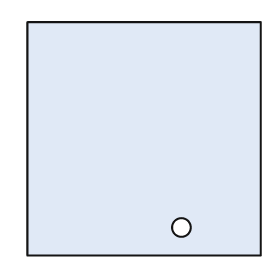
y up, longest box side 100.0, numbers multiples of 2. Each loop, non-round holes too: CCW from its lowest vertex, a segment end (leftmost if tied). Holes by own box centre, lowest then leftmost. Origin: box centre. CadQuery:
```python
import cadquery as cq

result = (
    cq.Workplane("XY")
    .moveTo(-50.0, -50.0)
    .lineTo(50.0, -50.0)
    .lineTo(50.0, 50.0)
    .lineTo(-50.0, 50.0)
    .close()
    .moveTo(16.0, -38.0)
    .circle(4.0)
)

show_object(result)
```